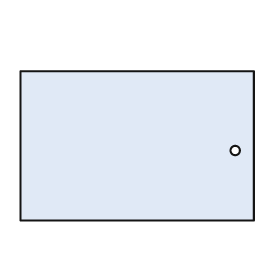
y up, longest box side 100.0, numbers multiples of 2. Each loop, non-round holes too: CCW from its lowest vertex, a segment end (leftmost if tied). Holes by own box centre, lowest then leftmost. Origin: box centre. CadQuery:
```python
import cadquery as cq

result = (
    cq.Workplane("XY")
    .moveTo(-50.0, -32.0)
    .lineTo(50.0, -32.0)
    .lineTo(50.0, 32.0)
    .lineTo(-50.0, 32.0)
    .close()
    .moveTo(42.0, -2.0)
    .circle(2.0)
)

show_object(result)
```